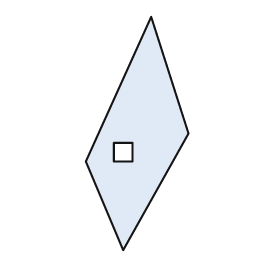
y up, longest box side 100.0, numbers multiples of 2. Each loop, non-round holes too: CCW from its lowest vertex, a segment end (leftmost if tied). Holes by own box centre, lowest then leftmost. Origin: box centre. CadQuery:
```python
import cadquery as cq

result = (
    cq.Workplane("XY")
    .moveTo(-6.0, -50.0)
    .lineTo(22.0, 0.0)
    .lineTo(6.0, 50.0)
    .lineTo(-22.0, -12.0)
    .close()
    .moveTo(-10.0, -12.0)
    .lineTo(-2.0, -12.0)
    .lineTo(-2.0, -4.0)
    .lineTo(-10.0, -4.0)
    .close()
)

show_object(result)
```